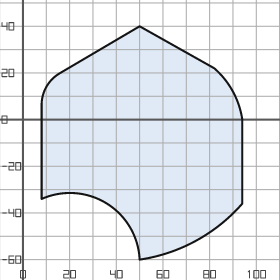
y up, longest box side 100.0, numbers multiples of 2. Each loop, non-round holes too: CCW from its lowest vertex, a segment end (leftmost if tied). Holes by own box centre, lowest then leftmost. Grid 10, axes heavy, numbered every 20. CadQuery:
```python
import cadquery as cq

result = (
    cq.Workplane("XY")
    .moveTo(50.0, -60.0)
    .threePointArc((74.0, -52.0), (94.0, -36.0))
    .lineTo(94.0, 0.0)
    .threePointArc((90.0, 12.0), (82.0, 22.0))
    .lineTo(50.0, 40.0)
    .lineTo(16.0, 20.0)
    .threePointArc((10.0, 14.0), (8.0, 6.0))
    .lineTo(8.0, -34.0)
    .threePointArc((36.0, -36.0), (50.0, -60.0))
    .close()
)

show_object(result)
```